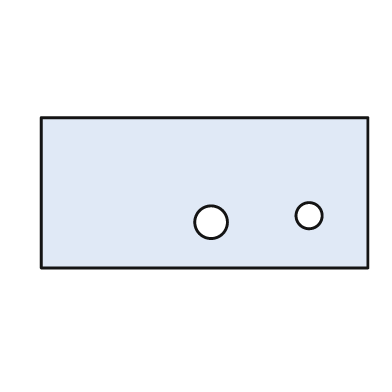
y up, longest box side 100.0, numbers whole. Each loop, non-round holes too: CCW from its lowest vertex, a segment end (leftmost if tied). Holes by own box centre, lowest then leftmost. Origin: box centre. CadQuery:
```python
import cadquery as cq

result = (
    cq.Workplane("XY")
    .moveTo(-50.0, -23.0)
    .lineTo(50.0, -23.0)
    .lineTo(50.0, 23.0)
    .lineTo(-50.0, 23.0)
    .close()
    .moveTo(2.0, -9.0)
    .circle(5.0)
    .moveTo(32.0, -7.0)
    .circle(4.0)
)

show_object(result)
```